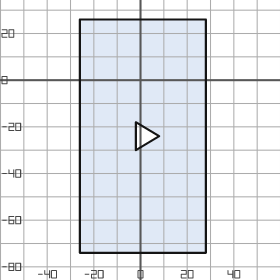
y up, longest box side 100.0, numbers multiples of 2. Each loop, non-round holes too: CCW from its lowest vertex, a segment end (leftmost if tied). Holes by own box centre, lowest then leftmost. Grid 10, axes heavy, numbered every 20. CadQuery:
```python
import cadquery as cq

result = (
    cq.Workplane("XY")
    .moveTo(-26.0, -74.0)
    .lineTo(28.0, -74.0)
    .lineTo(28.0, 26.0)
    .lineTo(-26.0, 26.0)
    .close()
    .moveTo(-2.0, -30.0)
    .lineTo(8.0, -24.0)
    .lineTo(-2.0, -18.0)
    .close()
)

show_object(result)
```